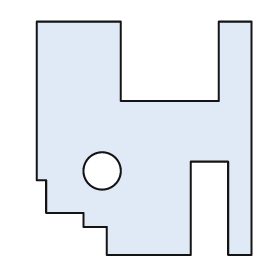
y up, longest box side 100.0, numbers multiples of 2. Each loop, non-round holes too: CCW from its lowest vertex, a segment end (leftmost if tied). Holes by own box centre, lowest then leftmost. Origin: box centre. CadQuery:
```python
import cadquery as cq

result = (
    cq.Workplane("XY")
    .moveTo(-16.0, -50.0)
    .lineTo(20.0, -50.0)
    .lineTo(20.0, -10.0)
    .lineTo(36.0, -10.0)
    .lineTo(36.0, -50.0)
    .lineTo(46.0, -50.0)
    .lineTo(46.0, 50.0)
    .lineTo(32.0, 50.0)
    .lineTo(32.0, 16.0)
    .lineTo(-10.0, 16.0)
    .lineTo(-10.0, 50.0)
    .lineTo(-46.0, 50.0)
    .lineTo(-46.0, -18.0)
    .lineTo(-42.0, -18.0)
    .lineTo(-42.0, -32.0)
    .lineTo(-26.0, -32.0)
    .lineTo(-26.0, -38.0)
    .lineTo(-16.0, -38.0)
    .close()
    .moveTo(-18.0, -14.0)
    .circle(8.0)
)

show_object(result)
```